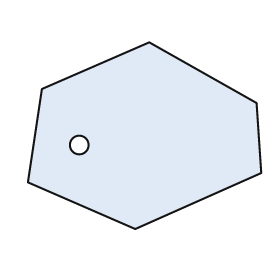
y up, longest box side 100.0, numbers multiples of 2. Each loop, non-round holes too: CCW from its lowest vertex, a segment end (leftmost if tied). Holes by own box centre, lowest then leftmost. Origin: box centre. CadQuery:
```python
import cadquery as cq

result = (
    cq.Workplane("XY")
    .moveTo(-4.0, -40.0)
    .lineTo(50.0, -16.0)
    .lineTo(48.0, 14.0)
    .lineTo(2.0, 40.0)
    .lineTo(-44.0, 20.0)
    .lineTo(-50.0, -20.0)
    .close()
    .moveTo(-28.0, -4.0)
    .circle(4.0)
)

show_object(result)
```